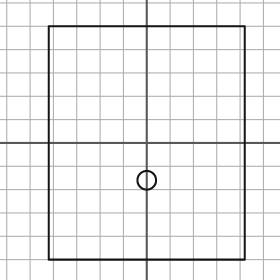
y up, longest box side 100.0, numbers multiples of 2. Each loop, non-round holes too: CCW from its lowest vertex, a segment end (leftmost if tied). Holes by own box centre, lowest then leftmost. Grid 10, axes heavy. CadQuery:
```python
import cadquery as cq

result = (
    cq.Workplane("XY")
    .moveTo(-42.0, -50.0)
    .lineTo(42.0, -50.0)
    .lineTo(42.0, 50.0)
    .lineTo(-42.0, 50.0)
    .close()
    .moveTo(0.0, -16.0)
    .circle(4.0)
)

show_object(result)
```